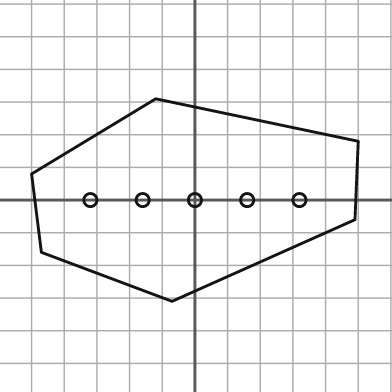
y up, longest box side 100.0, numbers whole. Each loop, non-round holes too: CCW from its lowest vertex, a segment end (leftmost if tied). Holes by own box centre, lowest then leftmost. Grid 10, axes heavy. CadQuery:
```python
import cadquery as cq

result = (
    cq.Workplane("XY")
    .moveTo(-7.0, -31.0)
    .lineTo(49.0, -6.0)
    .lineTo(50.0, 18.0)
    .lineTo(-12.0, 31.0)
    .lineTo(-50.0, 8.0)
    .lineTo(-47.0, -16.0)
    .close()
    .moveTo(-32.0, 0.0)
    .circle(2.0)
    .moveTo(-16.0, 0.0)
    .circle(2.0)
    .moveTo(0.0, 0.0)
    .circle(2.0)
    .moveTo(16.0, 0.0)
    .circle(2.0)
    .moveTo(32.0, 0.0)
    .circle(2.0)
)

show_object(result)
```